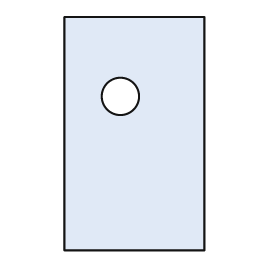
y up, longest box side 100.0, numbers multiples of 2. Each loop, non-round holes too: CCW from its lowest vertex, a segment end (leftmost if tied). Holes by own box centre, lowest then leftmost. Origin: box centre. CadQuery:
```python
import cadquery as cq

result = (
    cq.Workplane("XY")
    .moveTo(-30.0, -50.0)
    .lineTo(30.0, -50.0)
    .lineTo(30.0, 50.0)
    .lineTo(-30.0, 50.0)
    .close()
    .moveTo(-6.0, 16.0)
    .circle(8.0)
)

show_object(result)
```